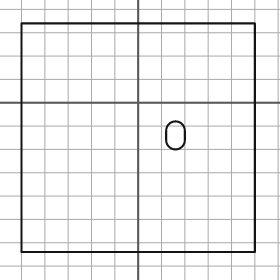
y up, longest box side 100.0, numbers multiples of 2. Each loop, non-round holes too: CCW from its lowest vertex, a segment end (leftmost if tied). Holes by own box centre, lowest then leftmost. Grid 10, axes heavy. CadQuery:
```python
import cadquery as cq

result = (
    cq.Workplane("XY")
    .moveTo(-50.0, -64.0)
    .lineTo(50.0, -64.0)
    .lineTo(50.0, 34.0)
    .lineTo(-50.0, 34.0)
    .close()
    .moveTo(12.0, -16.0)
    .threePointArc((16.0, -20.0), (20.0, -16.0))
    .lineTo(20.0, -12.0)
    .threePointArc((16.0, -8.0), (12.0, -12.0))
    .close()
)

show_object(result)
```